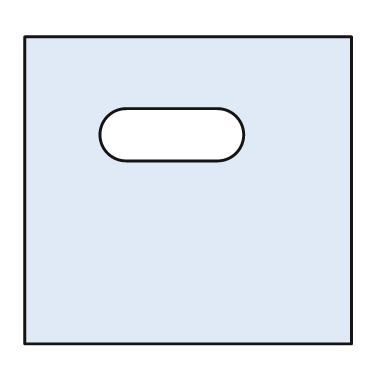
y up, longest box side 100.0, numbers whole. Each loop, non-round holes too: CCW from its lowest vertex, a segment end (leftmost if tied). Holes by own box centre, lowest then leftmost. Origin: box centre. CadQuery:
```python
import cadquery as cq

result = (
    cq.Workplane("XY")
    .moveTo(-50.0, -47.0)
    .lineTo(50.0, -47.0)
    .lineTo(50.0, 47.0)
    .lineTo(-50.0, 47.0)
    .close()
    .moveTo(-19.0, 9.0)
    .lineTo(9.0, 9.0)
    .threePointArc((17.0, 17.0), (9.0, 25.0))
    .lineTo(-19.0, 25.0)
    .threePointArc((-27.0, 17.0), (-19.0, 9.0))
    .close()
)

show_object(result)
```